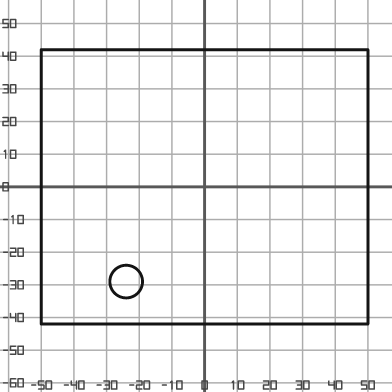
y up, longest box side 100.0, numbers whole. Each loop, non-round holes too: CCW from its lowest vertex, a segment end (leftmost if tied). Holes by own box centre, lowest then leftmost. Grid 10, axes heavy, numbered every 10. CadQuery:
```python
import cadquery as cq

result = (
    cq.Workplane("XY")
    .moveTo(-50.0, -42.0)
    .lineTo(50.0, -42.0)
    .lineTo(50.0, 42.0)
    .lineTo(-50.0, 42.0)
    .close()
    .moveTo(-24.0, -29.0)
    .circle(5.0)
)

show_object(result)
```